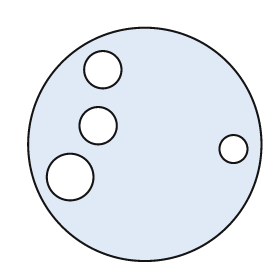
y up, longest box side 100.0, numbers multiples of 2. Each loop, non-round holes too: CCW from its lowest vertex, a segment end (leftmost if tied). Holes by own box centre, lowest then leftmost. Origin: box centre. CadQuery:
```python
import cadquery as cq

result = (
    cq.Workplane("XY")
    .moveTo(0.0, 0.0)
    .circle(50.0)
    .moveTo(-32.0, -14.0)
    .circle(10.0)
    .moveTo(38.0, -2.0)
    .circle(6.0)
    .moveTo(-20.0, 8.0)
    .circle(8.0)
    .moveTo(-18.0, 32.0)
    .circle(8.0)
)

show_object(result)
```